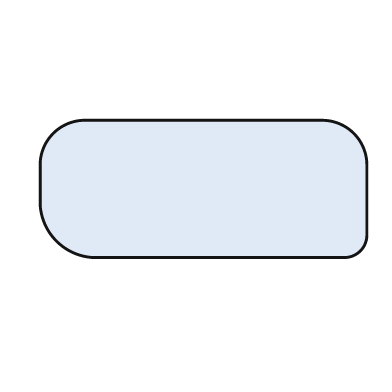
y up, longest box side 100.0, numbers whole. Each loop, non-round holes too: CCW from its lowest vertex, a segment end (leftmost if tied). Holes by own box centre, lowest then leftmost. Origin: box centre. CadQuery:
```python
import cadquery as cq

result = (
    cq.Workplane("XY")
    .moveTo(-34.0, -21.0)
    .lineTo(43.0, -21.0)
    .threePointArc((48.0, -19.0), (50.0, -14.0))
    .lineTo(50.0, 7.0)
    .threePointArc((46.0, 17.0), (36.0, 21.0))
    .lineTo(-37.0, 21.0)
    .threePointArc((-46.0, 17.0), (-50.0, 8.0))
    .lineTo(-50.0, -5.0)
    .threePointArc((-45.0, -16.0), (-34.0, -21.0))
    .close()
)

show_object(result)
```